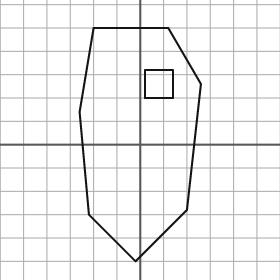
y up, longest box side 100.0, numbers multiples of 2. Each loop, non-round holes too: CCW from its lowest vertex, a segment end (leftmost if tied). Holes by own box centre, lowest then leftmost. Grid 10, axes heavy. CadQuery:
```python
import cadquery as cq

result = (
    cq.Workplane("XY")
    .moveTo(-2.0, -50.0)
    .lineTo(20.0, -28.0)
    .lineTo(26.0, 26.0)
    .lineTo(12.0, 50.0)
    .lineTo(-20.0, 50.0)
    .lineTo(-26.0, 14.0)
    .lineTo(-22.0, -30.0)
    .close()
    .moveTo(2.0, 20.0)
    .lineTo(14.0, 20.0)
    .lineTo(14.0, 32.0)
    .lineTo(2.0, 32.0)
    .close()
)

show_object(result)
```